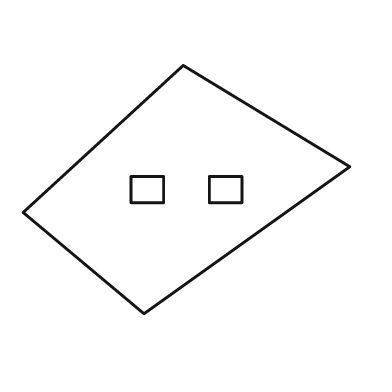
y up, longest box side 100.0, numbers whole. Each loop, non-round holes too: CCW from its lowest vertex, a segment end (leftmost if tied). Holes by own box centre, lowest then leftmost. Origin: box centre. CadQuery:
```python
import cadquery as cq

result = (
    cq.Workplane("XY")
    .moveTo(-13.0, -38.0)
    .lineTo(50.0, 7.0)
    .lineTo(-1.0, 38.0)
    .lineTo(-50.0, -7.0)
    .close()
    .moveTo(-17.0, -4.0)
    .lineTo(-7.0, -4.0)
    .lineTo(-7.0, 4.0)
    .lineTo(-17.0, 4.0)
    .close()
    .moveTo(7.0, -4.0)
    .lineTo(17.0, -4.0)
    .lineTo(17.0, 4.0)
    .lineTo(7.0, 4.0)
    .close()
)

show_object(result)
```